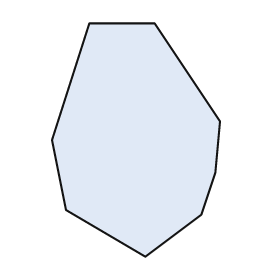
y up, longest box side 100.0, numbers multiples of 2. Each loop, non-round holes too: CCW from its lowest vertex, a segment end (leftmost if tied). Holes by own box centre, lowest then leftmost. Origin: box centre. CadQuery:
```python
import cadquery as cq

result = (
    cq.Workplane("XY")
    .moveTo(4.0, -50.0)
    .lineTo(28.0, -32.0)
    .lineTo(34.0, -14.0)
    .lineTo(36.0, 8.0)
    .lineTo(8.0, 50.0)
    .lineTo(-20.0, 50.0)
    .lineTo(-36.0, 0.0)
    .lineTo(-30.0, -30.0)
    .close()
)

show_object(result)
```